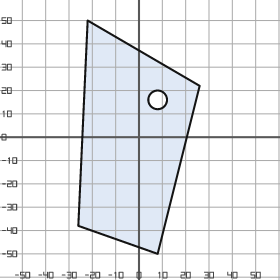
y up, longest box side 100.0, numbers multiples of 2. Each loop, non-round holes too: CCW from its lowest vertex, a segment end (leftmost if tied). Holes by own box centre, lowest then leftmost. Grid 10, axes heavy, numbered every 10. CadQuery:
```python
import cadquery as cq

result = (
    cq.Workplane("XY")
    .moveTo(8.0, -50.0)
    .lineTo(26.0, 22.0)
    .lineTo(-22.0, 50.0)
    .lineTo(-26.0, -38.0)
    .close()
    .moveTo(8.0, 16.0)
    .circle(4.0)
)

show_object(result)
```